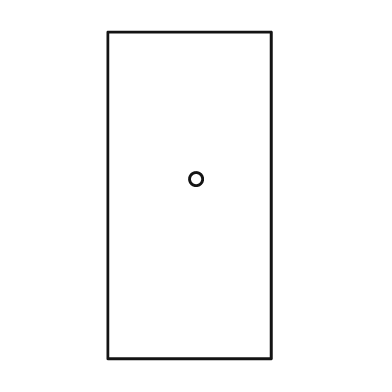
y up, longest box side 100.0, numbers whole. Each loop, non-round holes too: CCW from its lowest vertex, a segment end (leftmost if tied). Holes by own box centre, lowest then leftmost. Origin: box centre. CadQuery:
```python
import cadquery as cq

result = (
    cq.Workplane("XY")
    .moveTo(-25.0, -50.0)
    .lineTo(25.0, -50.0)
    .lineTo(25.0, 50.0)
    .lineTo(-25.0, 50.0)
    .close()
    .moveTo(2.0, 5.0)
    .circle(2.0)
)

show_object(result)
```